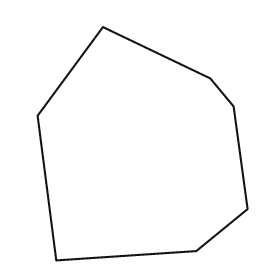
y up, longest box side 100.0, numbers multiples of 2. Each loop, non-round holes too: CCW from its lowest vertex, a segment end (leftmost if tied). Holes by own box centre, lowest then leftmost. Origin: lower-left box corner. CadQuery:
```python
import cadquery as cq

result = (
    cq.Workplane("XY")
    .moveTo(8.0, 0.0)
    .lineTo(68.0, 4.0)
    .lineTo(90.0, 22.0)
    .lineTo(84.0, 66.0)
    .lineTo(74.0, 78.0)
    .lineTo(28.0, 100.0)
    .lineTo(0.0, 62.0)
    .close()
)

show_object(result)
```